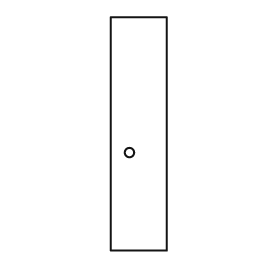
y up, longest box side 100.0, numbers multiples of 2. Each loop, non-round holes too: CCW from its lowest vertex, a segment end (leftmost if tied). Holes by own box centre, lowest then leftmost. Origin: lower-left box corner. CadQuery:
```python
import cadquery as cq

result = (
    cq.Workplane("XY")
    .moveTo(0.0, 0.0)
    .lineTo(24.0, 0.0)
    .lineTo(24.0, 100.0)
    .lineTo(0.0, 100.0)
    .close()
    .moveTo(8.0, 42.0)
    .circle(2.0)
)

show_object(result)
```